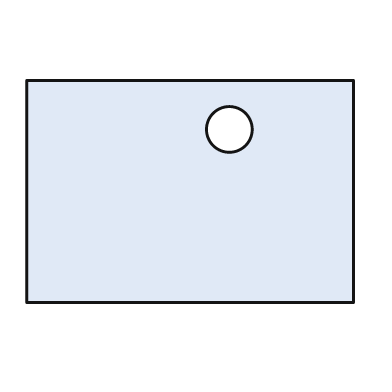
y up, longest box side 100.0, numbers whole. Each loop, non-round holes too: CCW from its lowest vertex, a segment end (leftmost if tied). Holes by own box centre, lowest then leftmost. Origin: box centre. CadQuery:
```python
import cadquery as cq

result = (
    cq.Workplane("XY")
    .moveTo(-50.0, -34.0)
    .lineTo(50.0, -34.0)
    .lineTo(50.0, 34.0)
    .lineTo(-50.0, 34.0)
    .close()
    .moveTo(12.0, 19.0)
    .circle(7.0)
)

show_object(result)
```